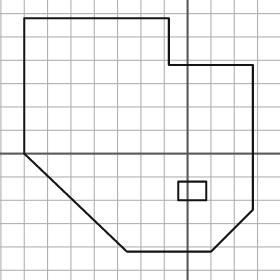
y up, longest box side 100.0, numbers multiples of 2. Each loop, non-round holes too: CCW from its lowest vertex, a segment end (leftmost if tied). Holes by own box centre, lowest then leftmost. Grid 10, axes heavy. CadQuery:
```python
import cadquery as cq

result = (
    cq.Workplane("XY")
    .moveTo(-26.0, -42.0)
    .lineTo(10.0, -42.0)
    .lineTo(28.0, -24.0)
    .lineTo(28.0, 38.0)
    .lineTo(-8.0, 38.0)
    .lineTo(-8.0, 58.0)
    .lineTo(-70.0, 58.0)
    .lineTo(-70.0, 0.0)
    .close()
    .moveTo(-4.0, -20.0)
    .lineTo(8.0, -20.0)
    .lineTo(8.0, -12.0)
    .lineTo(-4.0, -12.0)
    .close()
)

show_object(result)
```